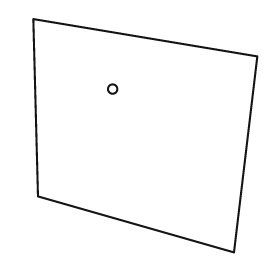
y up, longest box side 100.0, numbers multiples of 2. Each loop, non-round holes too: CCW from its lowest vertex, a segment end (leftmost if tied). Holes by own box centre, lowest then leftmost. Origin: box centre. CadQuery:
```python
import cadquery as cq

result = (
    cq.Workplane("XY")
    .moveTo(38.0, -50.0)
    .lineTo(48.0, 34.0)
    .lineTo(-48.0, 50.0)
    .lineTo(-46.0, -26.0)
    .close()
    .moveTo(-14.0, 20.0)
    .circle(2.0)
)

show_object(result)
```